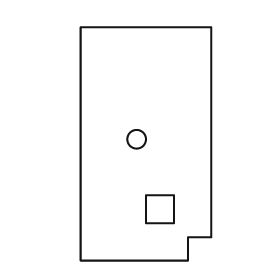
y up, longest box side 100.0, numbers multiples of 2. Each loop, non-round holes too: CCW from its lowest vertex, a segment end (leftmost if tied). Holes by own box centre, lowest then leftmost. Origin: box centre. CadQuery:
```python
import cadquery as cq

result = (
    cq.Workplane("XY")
    .moveTo(-28.0, -50.0)
    .lineTo(18.0, -50.0)
    .lineTo(18.0, -40.0)
    .lineTo(28.0, -40.0)
    .lineTo(28.0, 50.0)
    .lineTo(-28.0, 50.0)
    .close()
    .moveTo(0.0, -34.0)
    .lineTo(12.0, -34.0)
    .lineTo(12.0, -22.0)
    .lineTo(0.0, -22.0)
    .close()
    .moveTo(-4.0, 2.0)
    .circle(4.0)
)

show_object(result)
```